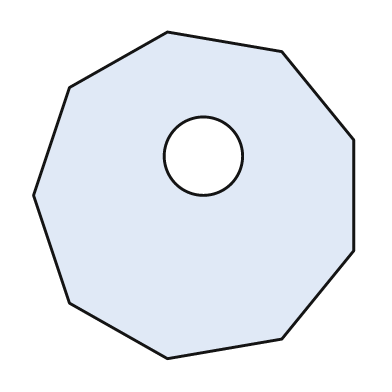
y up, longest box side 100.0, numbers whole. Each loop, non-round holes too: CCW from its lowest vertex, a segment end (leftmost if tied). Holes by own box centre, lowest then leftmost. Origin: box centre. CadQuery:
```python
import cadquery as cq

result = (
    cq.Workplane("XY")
    .moveTo(-8.0, -50.0)
    .lineTo(27.0, -44.0)
    .lineTo(49.0, -17.0)
    .lineTo(49.0, 17.0)
    .lineTo(27.0, 44.0)
    .lineTo(-8.0, 50.0)
    .lineTo(-38.0, 33.0)
    .lineTo(-49.0, 0.0)
    .lineTo(-38.0, -33.0)
    .close()
    .moveTo(3.0, 12.0)
    .circle(12.0)
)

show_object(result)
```